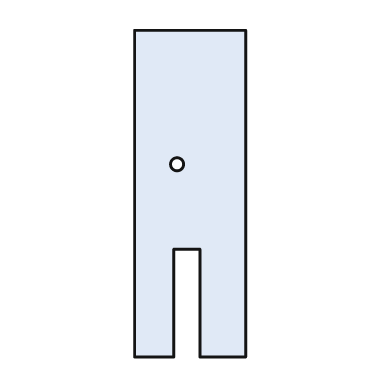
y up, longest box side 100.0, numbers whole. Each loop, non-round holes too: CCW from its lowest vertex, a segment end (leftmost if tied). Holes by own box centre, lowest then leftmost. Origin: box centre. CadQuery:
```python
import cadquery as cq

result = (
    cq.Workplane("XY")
    .moveTo(-17.0, -50.0)
    .lineTo(-5.0, -50.0)
    .lineTo(-5.0, -17.0)
    .lineTo(3.0, -17.0)
    .lineTo(3.0, -50.0)
    .lineTo(17.0, -50.0)
    .lineTo(17.0, 50.0)
    .lineTo(-17.0, 50.0)
    .close()
    .moveTo(-4.0, 9.0)
    .circle(2.0)
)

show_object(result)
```